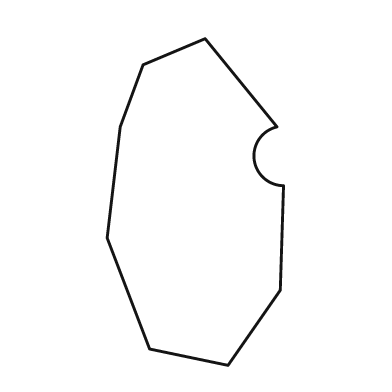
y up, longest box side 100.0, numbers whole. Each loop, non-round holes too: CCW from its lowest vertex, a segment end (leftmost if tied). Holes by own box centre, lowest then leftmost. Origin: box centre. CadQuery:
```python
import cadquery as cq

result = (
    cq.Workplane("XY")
    .moveTo(10.0, -50.0)
    .lineTo(26.0, -27.0)
    .lineTo(27.0, 5.0)
    .threePointArc((18.0, 13.0), (25.0, 23.0))
    .lineTo(3.0, 50.0)
    .lineTo(-16.0, 42.0)
    .lineTo(-23.0, 23.0)
    .lineTo(-27.0, -11.0)
    .lineTo(-14.0, -45.0)
    .close()
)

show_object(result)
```